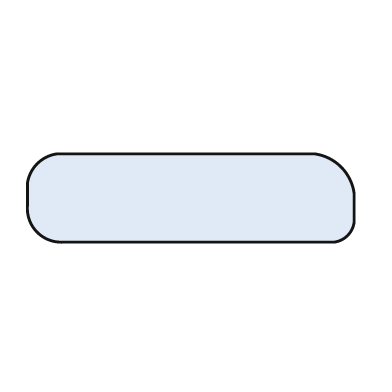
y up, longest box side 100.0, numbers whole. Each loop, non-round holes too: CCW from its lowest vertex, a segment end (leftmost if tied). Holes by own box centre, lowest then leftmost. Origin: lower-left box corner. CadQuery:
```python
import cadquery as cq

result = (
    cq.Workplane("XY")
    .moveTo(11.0, 0.0)
    .lineTo(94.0, 0.0)
    .threePointArc((98.0, 2.0), (100.0, 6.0))
    .lineTo(100.0, 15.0)
    .threePointArc((96.0, 23.0), (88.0, 27.0))
    .lineTo(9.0, 27.0)
    .threePointArc((3.0, 24.0), (0.0, 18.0))
    .lineTo(0.0, 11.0)
    .threePointArc((3.0, 3.0), (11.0, 0.0))
    .close()
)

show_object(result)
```